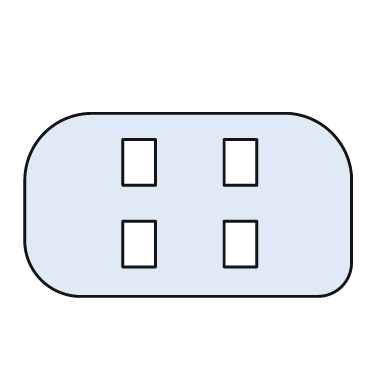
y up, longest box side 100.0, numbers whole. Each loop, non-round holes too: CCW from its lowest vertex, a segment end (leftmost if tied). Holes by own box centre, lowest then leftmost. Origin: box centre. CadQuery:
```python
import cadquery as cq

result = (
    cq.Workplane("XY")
    .moveTo(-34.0, -28.0)
    .lineTo(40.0, -28.0)
    .threePointArc((47.0, -25.0), (50.0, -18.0))
    .lineTo(50.0, 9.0)
    .threePointArc((44.0, 22.0), (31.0, 28.0))
    .lineTo(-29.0, 28.0)
    .threePointArc((-44.0, 22.0), (-50.0, 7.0))
    .lineTo(-50.0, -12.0)
    .threePointArc((-45.0, -23.0), (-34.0, -28.0))
    .close()
    .moveTo(-20.0, -19.0)
    .lineTo(-10.0, -19.0)
    .lineTo(-10.0, -5.0)
    .lineTo(-20.0, -5.0)
    .close()
    .moveTo(11.0, -19.0)
    .lineTo(21.0, -19.0)
    .lineTo(21.0, -5.0)
    .lineTo(11.0, -5.0)
    .close()
    .moveTo(-20.0, 6.0)
    .lineTo(-10.0, 6.0)
    .lineTo(-10.0, 20.0)
    .lineTo(-20.0, 20.0)
    .close()
    .moveTo(11.0, 6.0)
    .lineTo(21.0, 6.0)
    .lineTo(21.0, 20.0)
    .lineTo(11.0, 20.0)
    .close()
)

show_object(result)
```